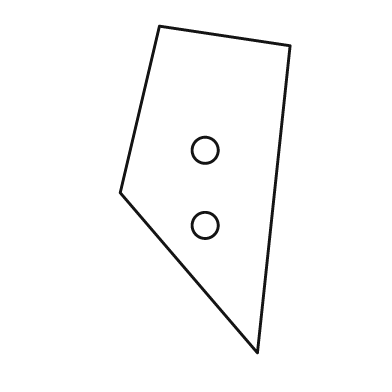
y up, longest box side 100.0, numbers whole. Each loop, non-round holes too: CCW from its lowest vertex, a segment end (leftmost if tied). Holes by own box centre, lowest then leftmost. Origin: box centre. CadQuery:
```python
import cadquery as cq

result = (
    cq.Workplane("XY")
    .moveTo(16.0, -50.0)
    .lineTo(26.0, 44.0)
    .lineTo(-14.0, 50.0)
    .lineTo(-26.0, -1.0)
    .close()
    .moveTo(0.0, -11.0)
    .circle(4.0)
    .moveTo(0.0, 12.0)
    .circle(4.0)
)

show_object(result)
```